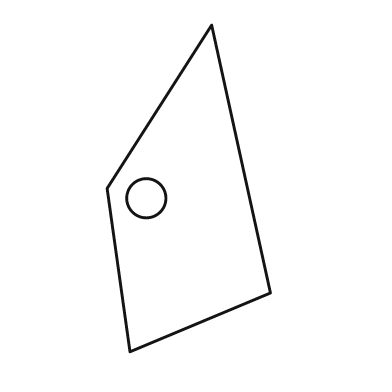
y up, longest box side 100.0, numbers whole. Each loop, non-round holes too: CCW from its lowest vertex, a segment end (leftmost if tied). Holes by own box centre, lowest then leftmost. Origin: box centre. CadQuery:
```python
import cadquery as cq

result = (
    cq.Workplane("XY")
    .moveTo(-18.0, -50.0)
    .lineTo(25.0, -32.0)
    .lineTo(7.0, 50.0)
    .lineTo(-25.0, 0.0)
    .close()
    .moveTo(-13.0, -3.0)
    .circle(6.0)
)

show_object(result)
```